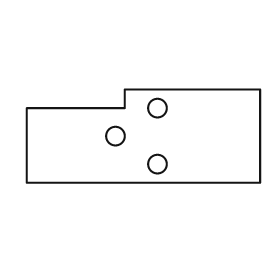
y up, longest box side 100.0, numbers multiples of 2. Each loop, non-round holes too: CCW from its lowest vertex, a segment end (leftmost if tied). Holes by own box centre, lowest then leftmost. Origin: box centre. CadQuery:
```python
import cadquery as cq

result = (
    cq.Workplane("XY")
    .moveTo(-50.0, -20.0)
    .lineTo(50.0, -20.0)
    .lineTo(50.0, 20.0)
    .lineTo(-8.0, 20.0)
    .lineTo(-8.0, 12.0)
    .lineTo(-50.0, 12.0)
    .close()
    .moveTo(6.0, -12.0)
    .circle(4.0)
    .moveTo(-12.0, 0.0)
    .circle(4.0)
    .moveTo(6.0, 12.0)
    .circle(4.0)
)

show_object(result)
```